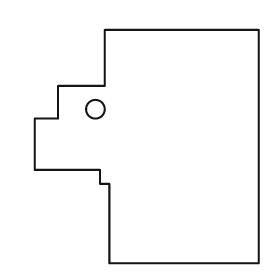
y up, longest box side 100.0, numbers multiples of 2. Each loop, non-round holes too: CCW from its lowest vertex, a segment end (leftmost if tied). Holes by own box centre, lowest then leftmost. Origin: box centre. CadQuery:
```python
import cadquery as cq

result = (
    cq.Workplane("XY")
    .moveTo(-16.0, -50.0)
    .lineTo(48.0, -50.0)
    .lineTo(48.0, 50.0)
    .lineTo(-18.0, 50.0)
    .lineTo(-18.0, 26.0)
    .lineTo(-38.0, 26.0)
    .lineTo(-38.0, 12.0)
    .lineTo(-48.0, 12.0)
    .lineTo(-48.0, -10.0)
    .lineTo(-20.0, -10.0)
    .lineTo(-20.0, -16.0)
    .lineTo(-16.0, -16.0)
    .close()
    .moveTo(-22.0, 16.0)
    .circle(4.0)
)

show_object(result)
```